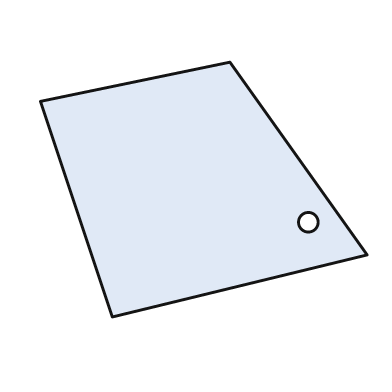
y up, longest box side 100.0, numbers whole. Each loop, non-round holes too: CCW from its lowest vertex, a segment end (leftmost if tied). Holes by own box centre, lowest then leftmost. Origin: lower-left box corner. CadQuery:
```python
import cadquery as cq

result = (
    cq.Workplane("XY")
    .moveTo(22.0, 0.0)
    .lineTo(100.0, 19.0)
    .lineTo(58.0, 78.0)
    .lineTo(0.0, 66.0)
    .close()
    .moveTo(82.0, 29.0)
    .circle(3.0)
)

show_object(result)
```